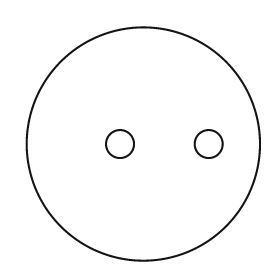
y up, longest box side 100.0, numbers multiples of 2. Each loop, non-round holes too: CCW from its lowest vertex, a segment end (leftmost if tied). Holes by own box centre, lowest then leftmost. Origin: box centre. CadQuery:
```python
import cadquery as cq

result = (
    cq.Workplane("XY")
    .moveTo(0.0, 0.0)
    .circle(50.0)
    .moveTo(-10.0, 0.0)
    .circle(6.0)
    .moveTo(28.0, 0.0)
    .circle(6.0)
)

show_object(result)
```